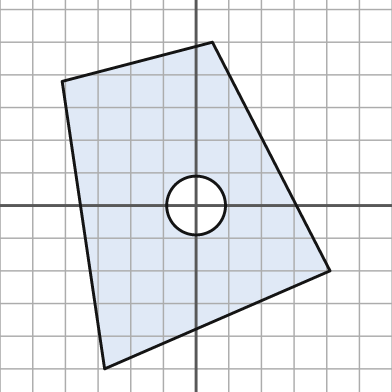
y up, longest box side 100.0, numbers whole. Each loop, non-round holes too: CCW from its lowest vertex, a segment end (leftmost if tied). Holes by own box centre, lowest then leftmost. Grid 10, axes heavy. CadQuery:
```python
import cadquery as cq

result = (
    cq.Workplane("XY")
    .moveTo(-28.0, -50.0)
    .lineTo(41.0, -20.0)
    .lineTo(5.0, 50.0)
    .lineTo(-41.0, 38.0)
    .close()
    .moveTo(0.0, 0.0)
    .circle(9.0)
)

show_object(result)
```